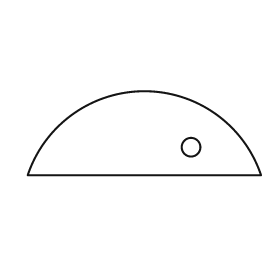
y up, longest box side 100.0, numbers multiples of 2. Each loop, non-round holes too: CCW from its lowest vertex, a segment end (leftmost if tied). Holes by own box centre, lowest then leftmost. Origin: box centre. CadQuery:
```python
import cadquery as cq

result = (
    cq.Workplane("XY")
    .moveTo(-50.0, -18.0)
    .lineTo(50.0, -18.0)
    .threePointArc((0.0, 18.0), (-50.0, -18.0))
    .close()
    .moveTo(20.0, -6.0)
    .circle(4.0)
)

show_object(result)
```